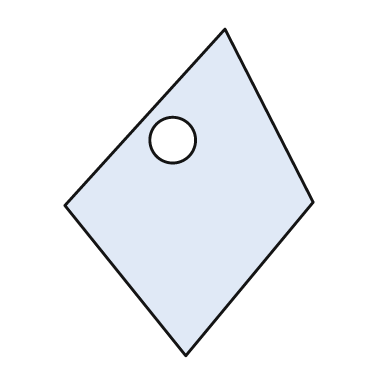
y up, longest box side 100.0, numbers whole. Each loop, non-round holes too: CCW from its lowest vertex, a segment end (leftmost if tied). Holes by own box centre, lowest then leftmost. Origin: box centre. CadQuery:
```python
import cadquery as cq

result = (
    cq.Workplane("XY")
    .moveTo(-1.0, -50.0)
    .lineTo(38.0, -3.0)
    .lineTo(11.0, 50.0)
    .lineTo(-38.0, -4.0)
    .close()
    .moveTo(-5.0, 16.0)
    .circle(7.0)
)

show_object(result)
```